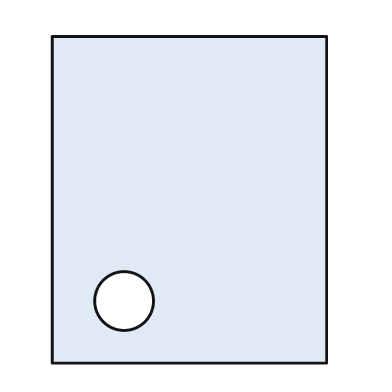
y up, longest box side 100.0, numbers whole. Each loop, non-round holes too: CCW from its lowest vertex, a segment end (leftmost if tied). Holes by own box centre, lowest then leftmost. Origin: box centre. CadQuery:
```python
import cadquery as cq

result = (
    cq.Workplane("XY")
    .moveTo(-42.0, -50.0)
    .lineTo(42.0, -50.0)
    .lineTo(42.0, 50.0)
    .lineTo(-42.0, 50.0)
    .close()
    .moveTo(-20.0, -31.0)
    .circle(9.0)
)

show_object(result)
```